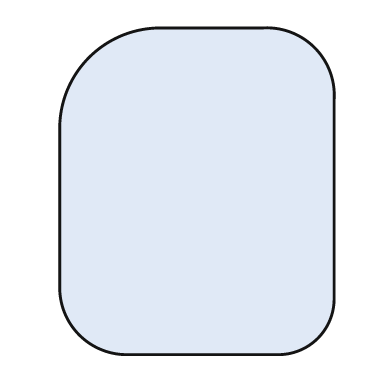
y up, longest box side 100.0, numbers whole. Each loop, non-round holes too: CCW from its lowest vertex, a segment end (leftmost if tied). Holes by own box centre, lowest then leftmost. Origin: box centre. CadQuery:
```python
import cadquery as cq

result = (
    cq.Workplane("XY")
    .moveTo(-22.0, -50.0)
    .lineTo(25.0, -50.0)
    .threePointArc((37.0, -45.0), (42.0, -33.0))
    .lineTo(42.0, 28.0)
    .threePointArc((36.0, 44.0), (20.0, 50.0))
    .lineTo(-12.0, 50.0)
    .threePointArc((-33.0, 41.0), (-42.0, 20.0))
    .lineTo(-42.0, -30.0)
    .threePointArc((-36.0, -44.0), (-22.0, -50.0))
    .close()
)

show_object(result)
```